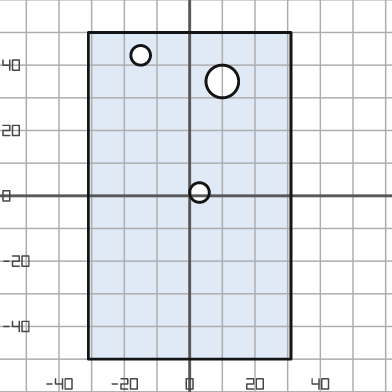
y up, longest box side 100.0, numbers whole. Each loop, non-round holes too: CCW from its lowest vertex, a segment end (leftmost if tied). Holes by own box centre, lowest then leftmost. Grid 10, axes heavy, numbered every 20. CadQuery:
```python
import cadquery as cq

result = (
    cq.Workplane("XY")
    .moveTo(-31.0, -50.0)
    .lineTo(31.0, -50.0)
    .lineTo(31.0, 50.0)
    .lineTo(-31.0, 50.0)
    .close()
    .moveTo(3.0, 1.0)
    .circle(3.0)
    .moveTo(10.0, 35.0)
    .circle(5.0)
    .moveTo(-15.0, 43.0)
    .circle(3.0)
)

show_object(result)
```